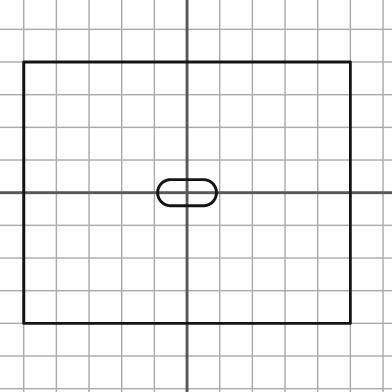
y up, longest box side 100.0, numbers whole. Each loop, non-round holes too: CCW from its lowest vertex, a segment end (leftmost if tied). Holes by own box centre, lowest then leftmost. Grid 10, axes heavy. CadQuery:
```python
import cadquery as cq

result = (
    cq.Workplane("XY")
    .moveTo(-50.0, -40.0)
    .lineTo(50.0, -40.0)
    .lineTo(50.0, 40.0)
    .lineTo(-50.0, 40.0)
    .close()
    .moveTo(-5.0, -4.0)
    .lineTo(5.0, -4.0)
    .threePointArc((9.0, 0.0), (5.0, 4.0))
    .lineTo(-5.0, 4.0)
    .threePointArc((-9.0, 0.0), (-5.0, -4.0))
    .close()
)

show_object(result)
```